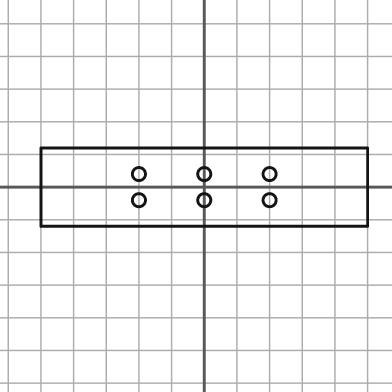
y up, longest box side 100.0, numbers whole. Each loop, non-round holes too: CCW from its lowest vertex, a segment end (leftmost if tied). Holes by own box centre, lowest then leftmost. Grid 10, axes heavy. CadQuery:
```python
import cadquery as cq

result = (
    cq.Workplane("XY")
    .moveTo(-50.0, -12.0)
    .lineTo(50.0, -12.0)
    .lineTo(50.0, 12.0)
    .lineTo(-50.0, 12.0)
    .close()
    .moveTo(-20.0, -4.0)
    .circle(2.0)
    .moveTo(0.0, -4.0)
    .circle(2.0)
    .moveTo(20.0, -4.0)
    .circle(2.0)
    .moveTo(-20.0, 4.0)
    .circle(2.0)
    .moveTo(0.0, 4.0)
    .circle(2.0)
    .moveTo(20.0, 4.0)
    .circle(2.0)
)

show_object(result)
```